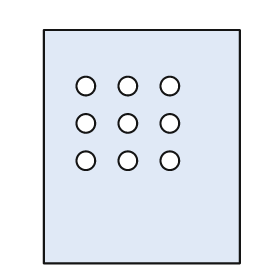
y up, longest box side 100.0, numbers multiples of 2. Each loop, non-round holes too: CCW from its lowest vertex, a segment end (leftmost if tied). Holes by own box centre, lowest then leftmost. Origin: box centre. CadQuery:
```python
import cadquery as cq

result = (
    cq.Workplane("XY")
    .moveTo(-42.0, -50.0)
    .lineTo(42.0, -50.0)
    .lineTo(42.0, 50.0)
    .lineTo(-42.0, 50.0)
    .close()
    .moveTo(-24.0, -6.0)
    .circle(4.0)
    .moveTo(-6.0, -6.0)
    .circle(4.0)
    .moveTo(12.0, -6.0)
    .circle(4.0)
    .moveTo(-24.0, 10.0)
    .circle(4.0)
    .moveTo(-6.0, 10.0)
    .circle(4.0)
    .moveTo(12.0, 10.0)
    .circle(4.0)
    .moveTo(-24.0, 26.0)
    .circle(4.0)
    .moveTo(-6.0, 26.0)
    .circle(4.0)
    .moveTo(12.0, 26.0)
    .circle(4.0)
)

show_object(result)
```